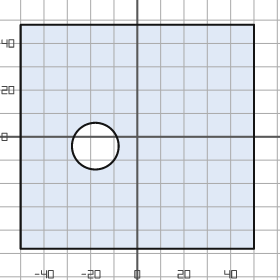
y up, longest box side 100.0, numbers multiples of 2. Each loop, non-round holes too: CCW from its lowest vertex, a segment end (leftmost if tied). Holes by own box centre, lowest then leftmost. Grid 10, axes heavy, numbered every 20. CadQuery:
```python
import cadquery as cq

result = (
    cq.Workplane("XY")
    .moveTo(-50.0, -48.0)
    .lineTo(50.0, -48.0)
    .lineTo(50.0, 48.0)
    .lineTo(-50.0, 48.0)
    .close()
    .moveTo(-18.0, -4.0)
    .circle(10.0)
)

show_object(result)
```